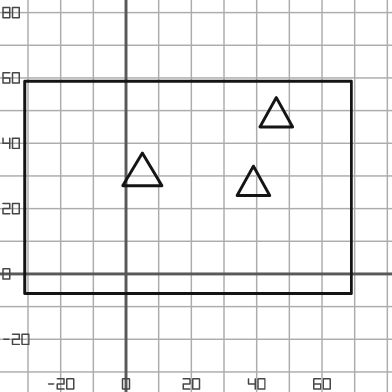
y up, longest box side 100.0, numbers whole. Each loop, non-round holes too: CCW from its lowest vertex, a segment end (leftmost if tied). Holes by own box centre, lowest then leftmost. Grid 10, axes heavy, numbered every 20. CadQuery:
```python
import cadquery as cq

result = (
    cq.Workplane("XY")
    .moveTo(-31.0, -6.0)
    .lineTo(69.0, -6.0)
    .lineTo(69.0, 59.0)
    .lineTo(-31.0, 59.0)
    .close()
    .moveTo(34.0, 24.0)
    .lineTo(44.0, 24.0)
    .lineTo(39.0, 33.0)
    .close()
    .moveTo(-1.0, 27.0)
    .lineTo(11.0, 27.0)
    .lineTo(5.0, 37.0)
    .close()
    .moveTo(41.0, 45.0)
    .lineTo(51.0, 45.0)
    .lineTo(46.0, 54.0)
    .close()
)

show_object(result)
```